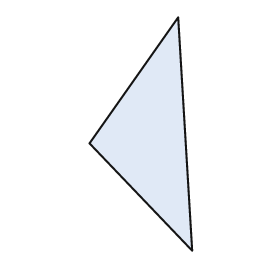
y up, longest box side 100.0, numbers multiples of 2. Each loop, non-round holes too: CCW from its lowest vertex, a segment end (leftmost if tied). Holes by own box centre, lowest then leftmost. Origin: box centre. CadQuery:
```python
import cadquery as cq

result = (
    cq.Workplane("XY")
    .moveTo(22.0, -50.0)
    .lineTo(16.0, 50.0)
    .lineTo(-22.0, -4.0)
    .close()
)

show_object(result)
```